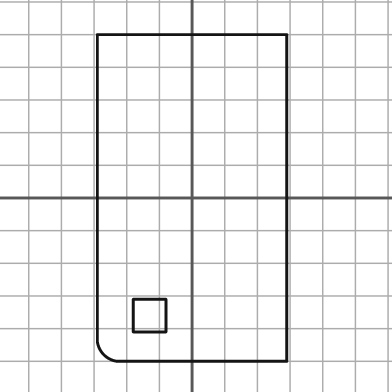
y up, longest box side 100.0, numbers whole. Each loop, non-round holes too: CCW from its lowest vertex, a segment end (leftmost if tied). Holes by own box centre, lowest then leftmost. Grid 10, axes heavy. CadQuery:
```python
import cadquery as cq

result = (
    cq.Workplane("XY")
    .moveTo(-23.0, -50.0)
    .lineTo(29.0, -50.0)
    .lineTo(29.0, 50.0)
    .lineTo(-29.0, 50.0)
    .lineTo(-29.0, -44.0)
    .threePointArc((-27.0, -48.0), (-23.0, -50.0))
    .close()
    .moveTo(-18.0, -41.0)
    .lineTo(-8.0, -41.0)
    .lineTo(-8.0, -31.0)
    .lineTo(-18.0, -31.0)
    .close()
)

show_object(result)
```